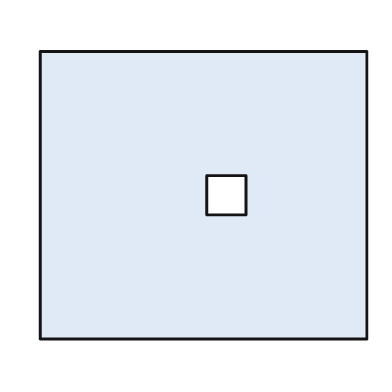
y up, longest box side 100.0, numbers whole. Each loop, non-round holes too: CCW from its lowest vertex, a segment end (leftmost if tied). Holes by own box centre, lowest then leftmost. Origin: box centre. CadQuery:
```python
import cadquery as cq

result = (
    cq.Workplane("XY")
    .moveTo(-50.0, -44.0)
    .lineTo(50.0, -44.0)
    .lineTo(50.0, 44.0)
    .lineTo(-50.0, 44.0)
    .close()
    .moveTo(1.0, -6.0)
    .lineTo(13.0, -6.0)
    .lineTo(13.0, 6.0)
    .lineTo(1.0, 6.0)
    .close()
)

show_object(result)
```